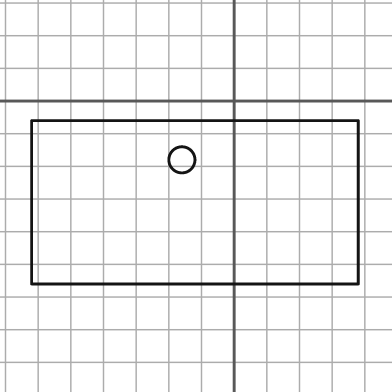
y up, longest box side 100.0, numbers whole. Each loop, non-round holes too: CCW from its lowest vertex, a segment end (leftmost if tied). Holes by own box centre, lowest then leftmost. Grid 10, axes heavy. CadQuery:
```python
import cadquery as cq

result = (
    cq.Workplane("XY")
    .moveTo(-62.0, -56.0)
    .lineTo(38.0, -56.0)
    .lineTo(38.0, -6.0)
    .lineTo(-62.0, -6.0)
    .close()
    .moveTo(-16.0, -18.0)
    .circle(4.0)
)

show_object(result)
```